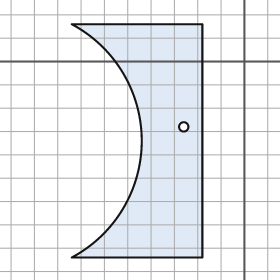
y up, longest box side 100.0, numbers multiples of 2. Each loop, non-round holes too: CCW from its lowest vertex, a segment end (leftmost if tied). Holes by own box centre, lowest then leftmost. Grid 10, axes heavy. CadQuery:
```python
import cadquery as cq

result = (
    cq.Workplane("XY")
    .moveTo(-74.0, -84.0)
    .lineTo(-18.0, -84.0)
    .lineTo(-18.0, 16.0)
    .lineTo(-74.0, 16.0)
    .threePointArc((-44.0, -34.0), (-74.0, -84.0))
    .close()
    .moveTo(-26.0, -28.0)
    .circle(2.0)
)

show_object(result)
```